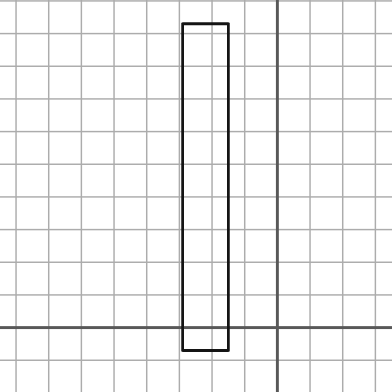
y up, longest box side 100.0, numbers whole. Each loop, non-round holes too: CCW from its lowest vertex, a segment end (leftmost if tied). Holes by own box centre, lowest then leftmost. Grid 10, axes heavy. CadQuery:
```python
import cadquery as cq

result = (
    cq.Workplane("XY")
    .moveTo(-29.0, -7.0)
    .lineTo(-15.0, -7.0)
    .lineTo(-15.0, 93.0)
    .lineTo(-29.0, 93.0)
    .close()
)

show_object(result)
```